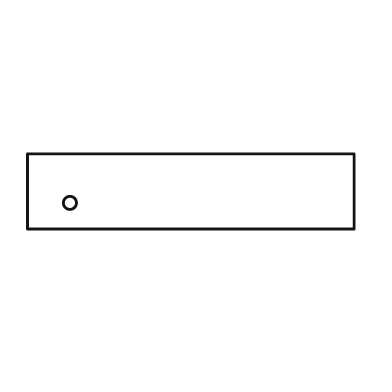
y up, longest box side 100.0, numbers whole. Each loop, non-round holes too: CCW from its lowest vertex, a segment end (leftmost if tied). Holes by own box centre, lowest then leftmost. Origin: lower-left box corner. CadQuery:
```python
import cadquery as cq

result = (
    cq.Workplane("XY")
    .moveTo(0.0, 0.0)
    .lineTo(100.0, 0.0)
    .lineTo(100.0, 23.0)
    .lineTo(0.0, 23.0)
    .close()
    .moveTo(13.0, 8.0)
    .circle(2.0)
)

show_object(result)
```